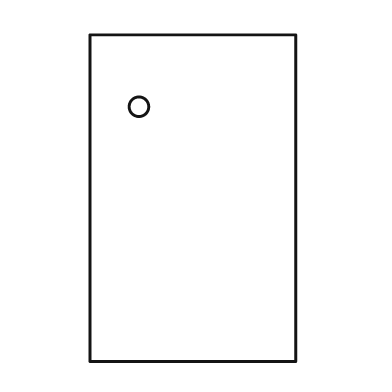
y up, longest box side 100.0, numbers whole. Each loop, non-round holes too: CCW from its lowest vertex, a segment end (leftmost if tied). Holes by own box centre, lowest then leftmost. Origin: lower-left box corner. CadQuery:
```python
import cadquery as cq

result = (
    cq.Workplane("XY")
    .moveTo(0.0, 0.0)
    .lineTo(63.0, 0.0)
    .lineTo(63.0, 100.0)
    .lineTo(0.0, 100.0)
    .close()
    .moveTo(15.0, 78.0)
    .circle(3.0)
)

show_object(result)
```